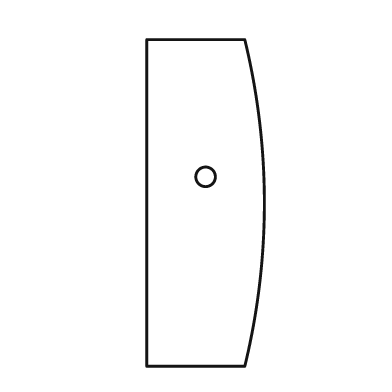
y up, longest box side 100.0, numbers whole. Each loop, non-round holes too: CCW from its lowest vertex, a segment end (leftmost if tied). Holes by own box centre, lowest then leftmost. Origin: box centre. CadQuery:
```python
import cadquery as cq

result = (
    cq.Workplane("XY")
    .moveTo(-18.0, -50.0)
    .lineTo(12.0, -50.0)
    .threePointArc((18.0, 0.0), (12.0, 50.0))
    .lineTo(-18.0, 50.0)
    .close()
    .moveTo(0.0, 8.0)
    .circle(3.0)
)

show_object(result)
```